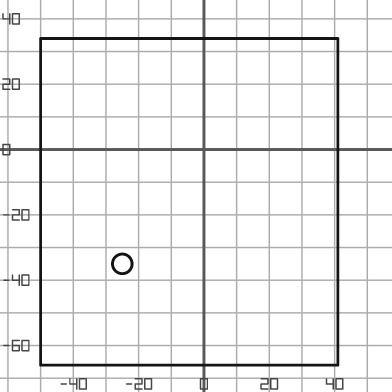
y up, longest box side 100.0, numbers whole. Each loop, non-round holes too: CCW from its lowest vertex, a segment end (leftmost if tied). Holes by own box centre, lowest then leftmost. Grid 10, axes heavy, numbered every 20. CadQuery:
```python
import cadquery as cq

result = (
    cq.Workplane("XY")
    .moveTo(-50.0, -66.0)
    .lineTo(41.0, -66.0)
    .lineTo(41.0, 34.0)
    .lineTo(-50.0, 34.0)
    .close()
    .moveTo(-25.0, -35.0)
    .circle(3.0)
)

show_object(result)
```